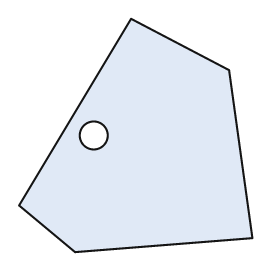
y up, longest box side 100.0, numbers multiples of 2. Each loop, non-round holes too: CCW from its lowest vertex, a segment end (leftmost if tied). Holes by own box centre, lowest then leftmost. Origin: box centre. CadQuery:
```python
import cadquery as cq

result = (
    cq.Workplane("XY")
    .moveTo(-26.0, -50.0)
    .lineTo(50.0, -44.0)
    .lineTo(40.0, 28.0)
    .lineTo(-2.0, 50.0)
    .lineTo(-50.0, -30.0)
    .close()
    .moveTo(-18.0, 0.0)
    .circle(6.0)
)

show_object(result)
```